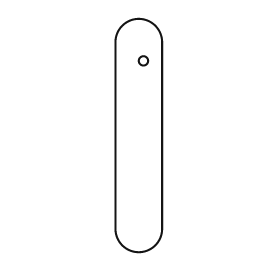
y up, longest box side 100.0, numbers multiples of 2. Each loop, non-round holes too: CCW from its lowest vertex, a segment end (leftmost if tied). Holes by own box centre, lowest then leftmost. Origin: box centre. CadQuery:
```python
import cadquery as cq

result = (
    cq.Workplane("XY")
    .moveTo(-10.0, -40.0)
    .threePointArc((0.0, -50.0), (10.0, -40.0))
    .lineTo(10.0, 40.0)
    .threePointArc((0.0, 50.0), (-10.0, 40.0))
    .close()
    .moveTo(2.0, 32.0)
    .circle(2.0)
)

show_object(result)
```